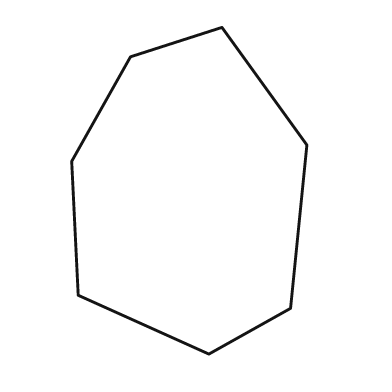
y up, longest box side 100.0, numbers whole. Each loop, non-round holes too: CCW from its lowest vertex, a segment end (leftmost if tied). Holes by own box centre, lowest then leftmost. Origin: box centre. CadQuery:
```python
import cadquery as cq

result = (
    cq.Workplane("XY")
    .moveTo(6.0, -50.0)
    .lineTo(31.0, -36.0)
    .lineTo(36.0, 14.0)
    .lineTo(10.0, 50.0)
    .lineTo(-18.0, 41.0)
    .lineTo(-36.0, 9.0)
    .lineTo(-34.0, -32.0)
    .close()
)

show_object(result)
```